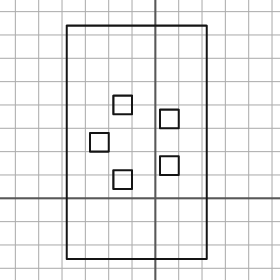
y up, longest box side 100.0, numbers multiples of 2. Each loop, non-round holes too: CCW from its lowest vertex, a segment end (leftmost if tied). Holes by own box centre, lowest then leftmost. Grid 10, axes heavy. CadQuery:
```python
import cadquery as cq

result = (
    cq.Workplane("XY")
    .moveTo(-38.0, -26.0)
    .lineTo(22.0, -26.0)
    .lineTo(22.0, 74.0)
    .lineTo(-38.0, 74.0)
    .close()
    .moveTo(-18.0, 4.0)
    .lineTo(-10.0, 4.0)
    .lineTo(-10.0, 12.0)
    .lineTo(-18.0, 12.0)
    .close()
    .moveTo(2.0, 10.0)
    .lineTo(10.0, 10.0)
    .lineTo(10.0, 18.0)
    .lineTo(2.0, 18.0)
    .close()
    .moveTo(-28.0, 20.0)
    .lineTo(-20.0, 20.0)
    .lineTo(-20.0, 28.0)
    .lineTo(-28.0, 28.0)
    .close()
    .moveTo(2.0, 30.0)
    .lineTo(10.0, 30.0)
    .lineTo(10.0, 38.0)
    .lineTo(2.0, 38.0)
    .close()
    .moveTo(-18.0, 36.0)
    .lineTo(-10.0, 36.0)
    .lineTo(-10.0, 44.0)
    .lineTo(-18.0, 44.0)
    .close()
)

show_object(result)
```